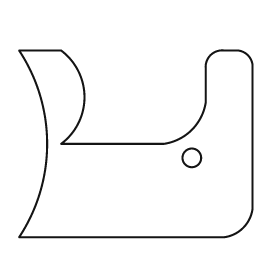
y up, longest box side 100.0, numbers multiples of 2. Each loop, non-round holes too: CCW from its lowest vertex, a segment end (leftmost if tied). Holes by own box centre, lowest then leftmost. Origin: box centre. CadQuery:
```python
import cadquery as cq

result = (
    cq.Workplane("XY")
    .moveTo(-50.0, -40.0)
    .lineTo(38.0, -40.0)
    .threePointArc((46.0, -36.0), (50.0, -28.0))
    .lineTo(50.0, 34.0)
    .threePointArc((48.0, 38.0), (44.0, 40.0))
    .lineTo(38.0, 40.0)
    .threePointArc((32.0, 38.0), (30.0, 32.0))
    .lineTo(30.0, 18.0)
    .threePointArc((24.0, 6.0), (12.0, 0.0))
    .lineTo(-32.0, 0.0)
    .threePointArc((-22.0, 20.0), (-32.0, 40.0))
    .lineTo(-50.0, 40.0)
    .threePointArc((-38.0, 0.0), (-50.0, -40.0))
    .close()
    .moveTo(24.0, -6.0)
    .circle(4.0)
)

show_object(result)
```